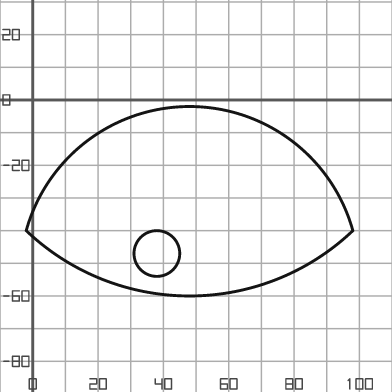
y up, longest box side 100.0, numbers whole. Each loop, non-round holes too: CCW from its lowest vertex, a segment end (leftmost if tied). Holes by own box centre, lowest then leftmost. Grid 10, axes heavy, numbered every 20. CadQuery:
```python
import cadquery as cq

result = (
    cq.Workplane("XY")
    .moveTo(-2.0, -40.0)
    .threePointArc((48.0, -60.0), (98.0, -40.0))
    .threePointArc((48.0, -2.0), (-2.0, -40.0))
    .close()
    .moveTo(38.0, -47.0)
    .circle(7.0)
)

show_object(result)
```